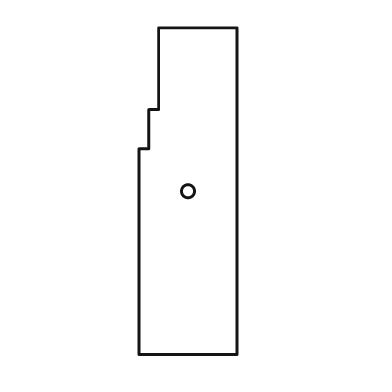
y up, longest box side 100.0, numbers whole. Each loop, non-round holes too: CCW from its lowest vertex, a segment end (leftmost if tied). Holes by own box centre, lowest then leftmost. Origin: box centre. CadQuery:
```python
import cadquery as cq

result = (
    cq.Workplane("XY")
    .moveTo(-15.0, -50.0)
    .lineTo(15.0, -50.0)
    .lineTo(15.0, 50.0)
    .lineTo(-9.0, 50.0)
    .lineTo(-9.0, 25.0)
    .lineTo(-12.0, 25.0)
    .lineTo(-12.0, 13.0)
    .lineTo(-15.0, 13.0)
    .close()
    .moveTo(0.0, 0.0)
    .circle(2.0)
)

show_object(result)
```